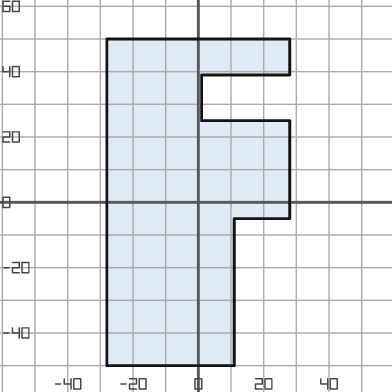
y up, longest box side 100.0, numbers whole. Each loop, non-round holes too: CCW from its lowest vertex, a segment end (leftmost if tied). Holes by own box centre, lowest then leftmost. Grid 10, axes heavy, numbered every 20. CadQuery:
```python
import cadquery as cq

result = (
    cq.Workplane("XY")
    .moveTo(-28.0, -50.0)
    .lineTo(11.0, -50.0)
    .lineTo(11.0, -5.0)
    .lineTo(28.0, -5.0)
    .lineTo(28.0, 25.0)
    .lineTo(1.0, 25.0)
    .lineTo(1.0, 39.0)
    .lineTo(28.0, 39.0)
    .lineTo(28.0, 50.0)
    .lineTo(-28.0, 50.0)
    .close()
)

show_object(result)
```